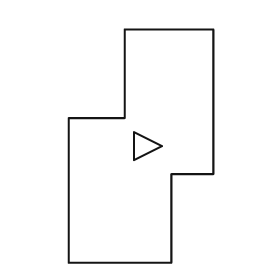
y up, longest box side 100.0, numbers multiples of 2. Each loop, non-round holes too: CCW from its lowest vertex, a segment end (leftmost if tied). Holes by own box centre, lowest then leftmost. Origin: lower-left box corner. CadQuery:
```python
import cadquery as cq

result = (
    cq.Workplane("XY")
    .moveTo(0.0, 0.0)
    .lineTo(44.0, 0.0)
    .lineTo(44.0, 38.0)
    .lineTo(62.0, 38.0)
    .lineTo(62.0, 100.0)
    .lineTo(24.0, 100.0)
    .lineTo(24.0, 62.0)
    .lineTo(0.0, 62.0)
    .close()
    .moveTo(28.0, 44.0)
    .lineTo(40.0, 50.0)
    .lineTo(28.0, 56.0)
    .close()
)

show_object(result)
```